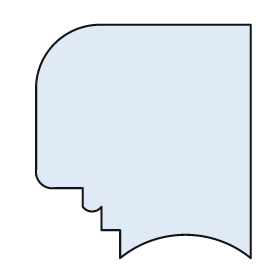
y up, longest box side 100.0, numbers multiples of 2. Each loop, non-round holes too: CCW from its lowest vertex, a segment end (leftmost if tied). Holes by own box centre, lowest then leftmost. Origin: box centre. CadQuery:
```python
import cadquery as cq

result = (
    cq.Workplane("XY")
    .moveTo(-10.0, -50.0)
    .threePointArc((18.0, -40.0), (46.0, -50.0))
    .lineTo(46.0, 50.0)
    .lineTo(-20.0, 50.0)
    .threePointArc((-38.0, 42.0), (-46.0, 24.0))
    .lineTo(-46.0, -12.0)
    .threePointArc((-44.0, -18.0), (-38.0, -20.0))
    .lineTo(-26.0, -20.0)
    .lineTo(-26.0, -28.0)
    .threePointArc((-22.0, -30.0), (-18.0, -28.0))
    .lineTo(-18.0, -38.0)
    .lineTo(-10.0, -38.0)
    .close()
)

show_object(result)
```